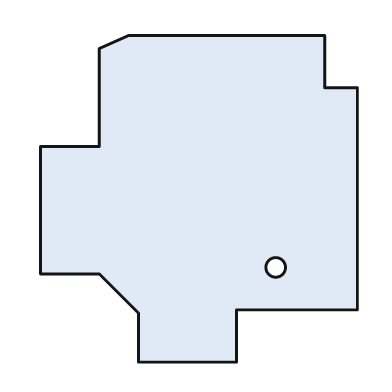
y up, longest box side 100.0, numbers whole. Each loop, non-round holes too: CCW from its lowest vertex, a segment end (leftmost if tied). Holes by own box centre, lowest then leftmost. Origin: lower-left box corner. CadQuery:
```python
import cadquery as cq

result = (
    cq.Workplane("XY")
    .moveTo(30.0, 0.0)
    .lineTo(60.0, 0.0)
    .lineTo(60.0, 16.0)
    .lineTo(97.0, 16.0)
    .lineTo(97.0, 84.0)
    .lineTo(87.0, 84.0)
    .lineTo(87.0, 100.0)
    .lineTo(27.0, 100.0)
    .lineTo(18.0, 96.0)
    .lineTo(18.0, 66.0)
    .lineTo(0.0, 66.0)
    .lineTo(0.0, 27.0)
    .lineTo(18.0, 27.0)
    .lineTo(30.0, 15.0)
    .close()
    .moveTo(72.0, 29.0)
    .circle(3.0)
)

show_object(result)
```